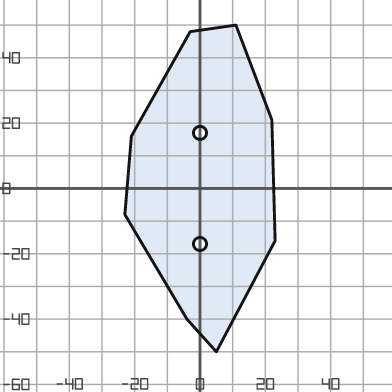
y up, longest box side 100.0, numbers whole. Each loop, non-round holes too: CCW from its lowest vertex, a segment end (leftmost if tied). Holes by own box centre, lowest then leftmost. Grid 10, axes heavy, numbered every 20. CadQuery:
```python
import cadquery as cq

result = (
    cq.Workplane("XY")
    .moveTo(5.0, -50.0)
    .lineTo(23.0, -16.0)
    .lineTo(22.0, 21.0)
    .lineTo(11.0, 50.0)
    .lineTo(-3.0, 48.0)
    .lineTo(-21.0, 16.0)
    .lineTo(-23.0, -8.0)
    .lineTo(-4.0, -40.0)
    .close()
    .moveTo(0.0, -17.0)
    .circle(2.0)
    .moveTo(0.0, 17.0)
    .circle(2.0)
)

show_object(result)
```